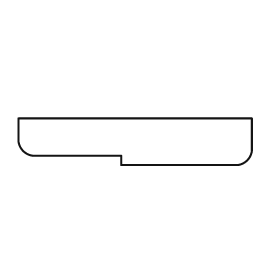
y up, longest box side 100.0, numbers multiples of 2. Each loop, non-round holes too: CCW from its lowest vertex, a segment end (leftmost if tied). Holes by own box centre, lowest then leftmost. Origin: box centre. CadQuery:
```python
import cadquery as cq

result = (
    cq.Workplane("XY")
    .moveTo(-6.0, -10.0)
    .lineTo(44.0, -10.0)
    .threePointArc((48.0, -8.0), (50.0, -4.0))
    .lineTo(50.0, 10.0)
    .lineTo(-50.0, 10.0)
    .lineTo(-50.0, 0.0)
    .threePointArc((-48.0, -4.0), (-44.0, -6.0))
    .lineTo(-6.0, -6.0)
    .close()
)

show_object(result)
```